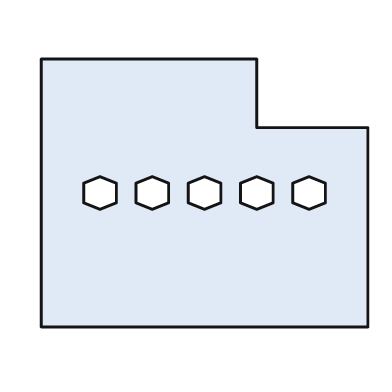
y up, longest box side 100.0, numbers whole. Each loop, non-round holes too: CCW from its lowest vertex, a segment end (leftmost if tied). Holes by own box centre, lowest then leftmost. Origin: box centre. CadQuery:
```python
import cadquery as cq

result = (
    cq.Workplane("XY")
    .moveTo(-50.0, -41.0)
    .lineTo(50.0, -41.0)
    .lineTo(50.0, 20.0)
    .lineTo(16.0, 20.0)
    .lineTo(16.0, 41.0)
    .lineTo(-50.0, 41.0)
    .close()
    .moveTo(-32.0, -5.0)
    .lineTo(-27.0, -3.0)
    .lineTo(-27.0, 3.0)
    .lineTo(-32.0, 5.0)
    .lineTo(-37.0, 3.0)
    .lineTo(-37.0, -3.0)
    .close()
    .moveTo(-16.0, -5.0)
    .lineTo(-11.0, -3.0)
    .lineTo(-11.0, 3.0)
    .lineTo(-16.0, 5.0)
    .lineTo(-21.0, 3.0)
    .lineTo(-21.0, -3.0)
    .close()
    .moveTo(0.0, -5.0)
    .lineTo(5.0, -3.0)
    .lineTo(5.0, 3.0)
    .lineTo(0.0, 5.0)
    .lineTo(-5.0, 3.0)
    .lineTo(-5.0, -3.0)
    .close()
    .moveTo(16.0, -5.0)
    .lineTo(21.0, -3.0)
    .lineTo(21.0, 3.0)
    .lineTo(16.0, 5.0)
    .lineTo(11.0, 3.0)
    .lineTo(11.0, -3.0)
    .close()
    .moveTo(32.0, -5.0)
    .lineTo(37.0, -3.0)
    .lineTo(37.0, 3.0)
    .lineTo(32.0, 5.0)
    .lineTo(27.0, 3.0)
    .lineTo(27.0, -3.0)
    .close()
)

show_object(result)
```